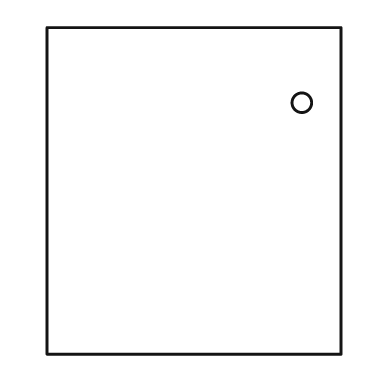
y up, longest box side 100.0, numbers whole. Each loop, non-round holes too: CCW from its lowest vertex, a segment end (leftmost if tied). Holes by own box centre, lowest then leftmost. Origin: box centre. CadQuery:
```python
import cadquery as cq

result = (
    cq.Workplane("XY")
    .moveTo(-45.0, -50.0)
    .lineTo(45.0, -50.0)
    .lineTo(45.0, 50.0)
    .lineTo(-45.0, 50.0)
    .close()
    .moveTo(33.0, 27.0)
    .circle(3.0)
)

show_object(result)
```